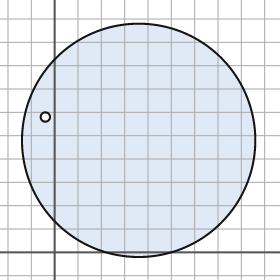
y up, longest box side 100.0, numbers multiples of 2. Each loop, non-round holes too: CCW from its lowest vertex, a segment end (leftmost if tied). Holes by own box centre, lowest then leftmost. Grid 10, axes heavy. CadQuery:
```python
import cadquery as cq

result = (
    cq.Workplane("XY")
    .moveTo(36.0, 48.0)
    .circle(50.0)
    .moveTo(-4.0, 58.0)
    .circle(2.0)
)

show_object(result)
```